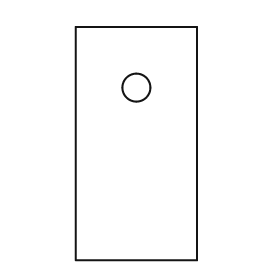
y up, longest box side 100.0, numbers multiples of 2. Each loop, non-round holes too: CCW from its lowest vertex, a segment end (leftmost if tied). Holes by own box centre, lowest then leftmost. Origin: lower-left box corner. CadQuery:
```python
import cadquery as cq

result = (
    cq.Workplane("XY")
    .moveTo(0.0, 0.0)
    .lineTo(52.0, 0.0)
    .lineTo(52.0, 100.0)
    .lineTo(0.0, 100.0)
    .close()
    .moveTo(26.0, 74.0)
    .circle(6.0)
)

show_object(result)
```